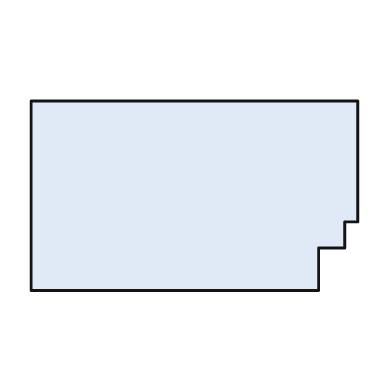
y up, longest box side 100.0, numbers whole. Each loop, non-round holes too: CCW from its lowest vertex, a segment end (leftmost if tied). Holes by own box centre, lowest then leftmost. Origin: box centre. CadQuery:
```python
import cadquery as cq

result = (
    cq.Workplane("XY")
    .moveTo(-50.0, -29.0)
    .lineTo(38.0, -29.0)
    .lineTo(38.0, -16.0)
    .lineTo(46.0, -16.0)
    .lineTo(46.0, -8.0)
    .lineTo(50.0, -8.0)
    .lineTo(50.0, 29.0)
    .lineTo(-50.0, 29.0)
    .close()
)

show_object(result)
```